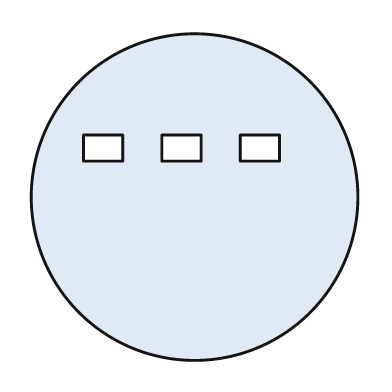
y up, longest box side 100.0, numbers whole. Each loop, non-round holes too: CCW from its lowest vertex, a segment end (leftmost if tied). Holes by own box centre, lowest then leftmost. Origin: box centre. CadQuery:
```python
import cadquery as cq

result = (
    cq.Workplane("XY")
    .moveTo(0.0, 0.0)
    .circle(50.0)
    .moveTo(-34.0, 11.0)
    .lineTo(-22.0, 11.0)
    .lineTo(-22.0, 19.0)
    .lineTo(-34.0, 19.0)
    .close()
    .moveTo(-10.0, 11.0)
    .lineTo(2.0, 11.0)
    .lineTo(2.0, 19.0)
    .lineTo(-10.0, 19.0)
    .close()
    .moveTo(14.0, 11.0)
    .lineTo(26.0, 11.0)
    .lineTo(26.0, 19.0)
    .lineTo(14.0, 19.0)
    .close()
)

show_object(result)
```